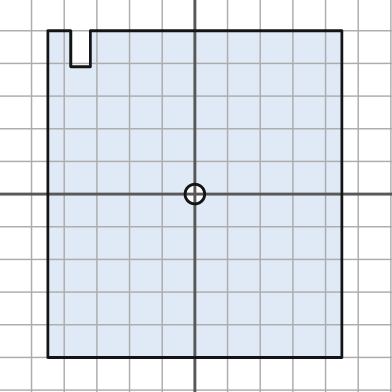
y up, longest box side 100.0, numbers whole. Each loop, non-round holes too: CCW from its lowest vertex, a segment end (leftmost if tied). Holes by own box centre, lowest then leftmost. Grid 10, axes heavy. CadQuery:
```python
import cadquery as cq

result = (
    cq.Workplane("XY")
    .moveTo(-45.0, -50.0)
    .lineTo(45.0, -50.0)
    .lineTo(45.0, 50.0)
    .lineTo(-32.0, 50.0)
    .lineTo(-32.0, 39.0)
    .lineTo(-38.0, 39.0)
    .lineTo(-38.0, 50.0)
    .lineTo(-45.0, 50.0)
    .close()
    .moveTo(0.0, 0.0)
    .circle(3.0)
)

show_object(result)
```